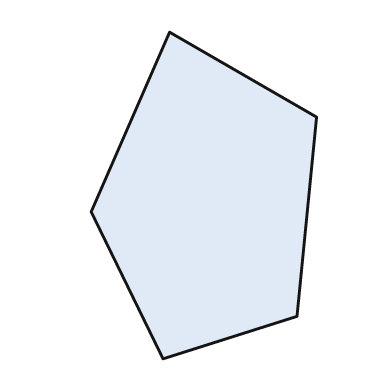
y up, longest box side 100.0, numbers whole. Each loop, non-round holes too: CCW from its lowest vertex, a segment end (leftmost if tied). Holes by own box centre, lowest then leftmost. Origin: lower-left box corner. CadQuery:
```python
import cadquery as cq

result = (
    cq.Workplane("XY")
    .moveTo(22.0, 0.0)
    .lineTo(63.0, 13.0)
    .lineTo(69.0, 74.0)
    .lineTo(24.0, 100.0)
    .lineTo(0.0, 45.0)
    .close()
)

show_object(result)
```